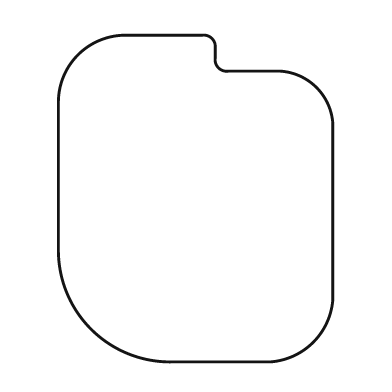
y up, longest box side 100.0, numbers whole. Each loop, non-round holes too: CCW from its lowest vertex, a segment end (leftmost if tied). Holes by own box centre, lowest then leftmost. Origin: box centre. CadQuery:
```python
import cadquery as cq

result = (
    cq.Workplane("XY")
    .moveTo(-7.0, -50.0)
    .lineTo(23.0, -50.0)
    .threePointArc((36.0, -44.0), (42.0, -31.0))
    .lineTo(42.0, 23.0)
    .threePointArc((37.0, 34.0), (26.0, 39.0))
    .lineTo(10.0, 39.0)
    .threePointArc((7.0, 40.0), (6.0, 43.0))
    .lineTo(6.0, 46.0)
    .threePointArc((5.0, 49.0), (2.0, 50.0))
    .lineTo(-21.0, 50.0)
    .threePointArc((-36.0, 44.0), (-42.0, 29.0))
    .lineTo(-42.0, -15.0)
    .threePointArc((-32.0, -40.0), (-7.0, -50.0))
    .close()
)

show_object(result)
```